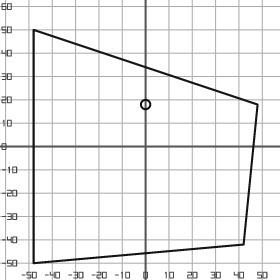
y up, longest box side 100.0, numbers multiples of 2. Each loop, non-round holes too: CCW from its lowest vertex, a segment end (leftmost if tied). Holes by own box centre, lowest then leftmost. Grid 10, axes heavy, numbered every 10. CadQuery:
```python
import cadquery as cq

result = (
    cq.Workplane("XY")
    .moveTo(-48.0, -50.0)
    .lineTo(42.0, -42.0)
    .lineTo(48.0, 18.0)
    .lineTo(-48.0, 50.0)
    .close()
    .moveTo(0.0, 18.0)
    .circle(2.0)
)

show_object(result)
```